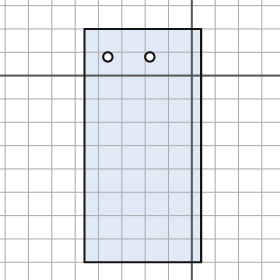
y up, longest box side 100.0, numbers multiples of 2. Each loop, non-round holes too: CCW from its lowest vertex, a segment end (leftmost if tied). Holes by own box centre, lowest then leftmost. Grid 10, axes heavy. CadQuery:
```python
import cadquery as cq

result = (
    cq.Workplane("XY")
    .moveTo(-46.0, -80.0)
    .lineTo(4.0, -80.0)
    .lineTo(4.0, 20.0)
    .lineTo(-46.0, 20.0)
    .close()
    .moveTo(-36.0, 8.0)
    .circle(2.0)
    .moveTo(-18.0, 8.0)
    .circle(2.0)
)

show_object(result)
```